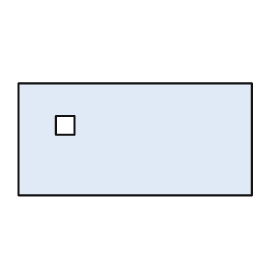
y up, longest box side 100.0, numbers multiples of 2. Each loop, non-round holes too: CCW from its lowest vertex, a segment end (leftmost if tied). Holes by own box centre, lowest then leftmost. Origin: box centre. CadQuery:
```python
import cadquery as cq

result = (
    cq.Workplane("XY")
    .moveTo(-50.0, -24.0)
    .lineTo(50.0, -24.0)
    .lineTo(50.0, 24.0)
    .lineTo(-50.0, 24.0)
    .close()
    .moveTo(-34.0, 2.0)
    .lineTo(-26.0, 2.0)
    .lineTo(-26.0, 10.0)
    .lineTo(-34.0, 10.0)
    .close()
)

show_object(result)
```